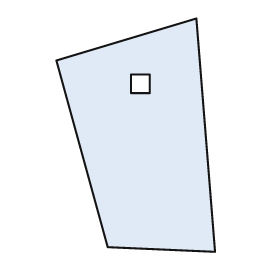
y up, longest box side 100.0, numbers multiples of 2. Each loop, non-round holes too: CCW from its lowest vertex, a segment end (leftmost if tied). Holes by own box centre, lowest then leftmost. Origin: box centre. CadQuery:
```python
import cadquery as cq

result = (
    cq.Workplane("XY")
    .moveTo(34.0, -50.0)
    .lineTo(26.0, 50.0)
    .lineTo(-34.0, 32.0)
    .lineTo(-12.0, -48.0)
    .close()
    .moveTo(-2.0, 18.0)
    .lineTo(6.0, 18.0)
    .lineTo(6.0, 26.0)
    .lineTo(-2.0, 26.0)
    .close()
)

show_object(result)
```